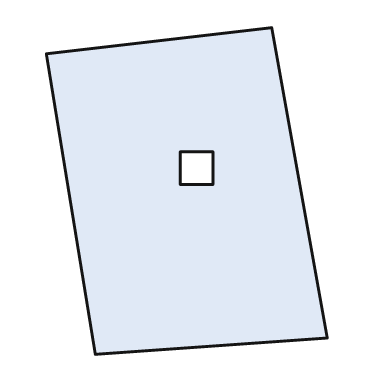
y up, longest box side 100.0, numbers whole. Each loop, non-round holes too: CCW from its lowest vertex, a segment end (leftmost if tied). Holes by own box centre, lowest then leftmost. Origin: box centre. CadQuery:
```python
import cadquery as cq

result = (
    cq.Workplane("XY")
    .moveTo(-28.0, -50.0)
    .lineTo(43.0, -45.0)
    .lineTo(26.0, 50.0)
    .lineTo(-43.0, 42.0)
    .close()
    .moveTo(-2.0, 2.0)
    .lineTo(8.0, 2.0)
    .lineTo(8.0, 12.0)
    .lineTo(-2.0, 12.0)
    .close()
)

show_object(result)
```